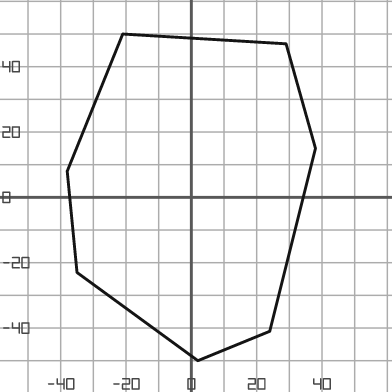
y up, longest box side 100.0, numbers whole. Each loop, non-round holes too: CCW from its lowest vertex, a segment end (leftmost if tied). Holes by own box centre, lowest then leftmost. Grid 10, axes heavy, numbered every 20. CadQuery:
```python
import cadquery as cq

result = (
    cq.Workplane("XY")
    .moveTo(2.0, -50.0)
    .lineTo(24.0, -41.0)
    .lineTo(38.0, 15.0)
    .lineTo(29.0, 47.0)
    .lineTo(-21.0, 50.0)
    .lineTo(-38.0, 8.0)
    .lineTo(-35.0, -23.0)
    .close()
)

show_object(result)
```